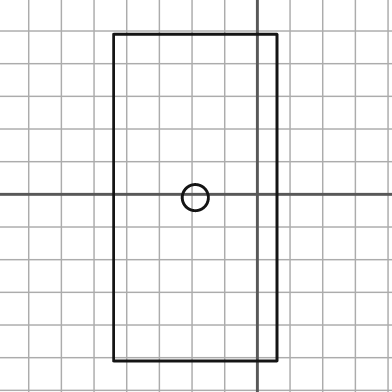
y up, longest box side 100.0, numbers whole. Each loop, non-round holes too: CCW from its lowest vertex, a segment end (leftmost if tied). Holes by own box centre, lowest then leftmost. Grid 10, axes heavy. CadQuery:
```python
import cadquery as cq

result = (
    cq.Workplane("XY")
    .moveTo(-44.0, -51.0)
    .lineTo(6.0, -51.0)
    .lineTo(6.0, 49.0)
    .lineTo(-44.0, 49.0)
    .close()
    .moveTo(-19.0, -1.0)
    .circle(4.0)
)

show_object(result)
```